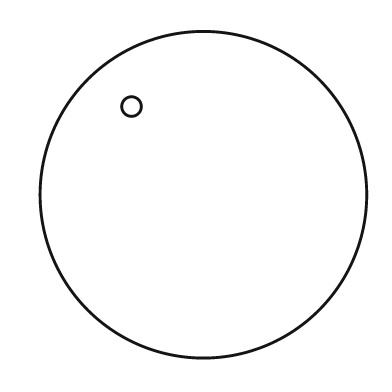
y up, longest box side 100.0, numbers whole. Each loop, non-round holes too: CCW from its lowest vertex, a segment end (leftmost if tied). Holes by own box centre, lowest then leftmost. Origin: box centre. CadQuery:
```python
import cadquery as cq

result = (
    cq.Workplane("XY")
    .moveTo(0.0, 0.0)
    .circle(50.0)
    .moveTo(-22.0, 27.0)
    .circle(3.0)
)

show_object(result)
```